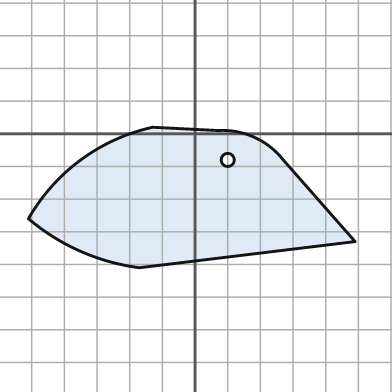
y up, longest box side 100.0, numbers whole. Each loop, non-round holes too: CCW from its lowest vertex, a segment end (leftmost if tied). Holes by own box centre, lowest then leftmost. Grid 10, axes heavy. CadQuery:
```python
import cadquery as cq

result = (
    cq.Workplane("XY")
    .moveTo(-17.0, -41.0)
    .lineTo(49.0, -33.0)
    .lineTo(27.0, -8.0)
    .threePointArc((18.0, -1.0), (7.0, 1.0))
    .lineTo(-13.0, 2.0)
    .threePointArc((-35.0, -8.0), (-51.0, -26.0))
    .threePointArc((-35.0, -36.0), (-17.0, -41.0))
    .close()
    .moveTo(10.0, -8.0)
    .circle(2.0)
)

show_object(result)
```